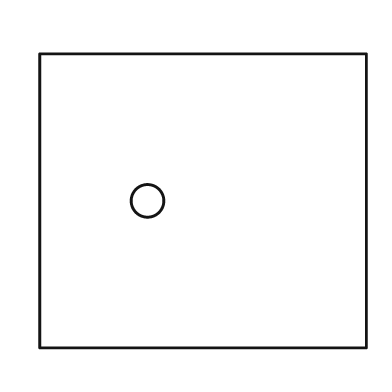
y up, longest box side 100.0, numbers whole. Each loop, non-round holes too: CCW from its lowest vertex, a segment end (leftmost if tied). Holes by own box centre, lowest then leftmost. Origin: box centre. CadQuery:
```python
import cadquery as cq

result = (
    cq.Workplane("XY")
    .moveTo(-50.0, -45.0)
    .lineTo(50.0, -45.0)
    .lineTo(50.0, 45.0)
    .lineTo(-50.0, 45.0)
    .close()
    .moveTo(-17.0, 0.0)
    .circle(5.0)
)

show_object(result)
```